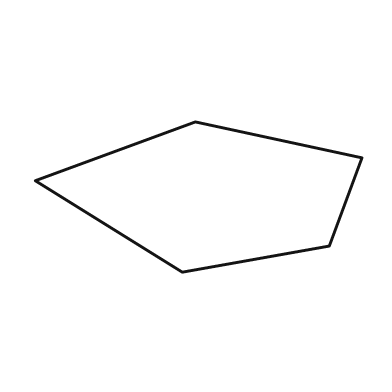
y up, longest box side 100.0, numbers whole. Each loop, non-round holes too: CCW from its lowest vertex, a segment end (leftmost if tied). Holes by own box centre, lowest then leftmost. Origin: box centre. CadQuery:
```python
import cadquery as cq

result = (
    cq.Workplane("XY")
    .moveTo(-5.0, -23.0)
    .lineTo(40.0, -15.0)
    .lineTo(50.0, 12.0)
    .lineTo(-1.0, 23.0)
    .lineTo(-50.0, 5.0)
    .close()
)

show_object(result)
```